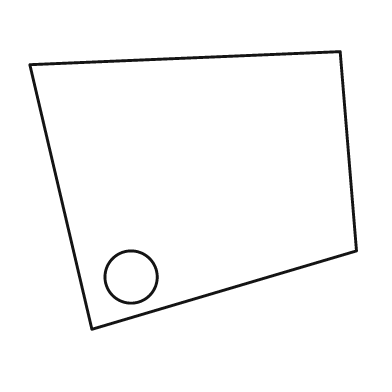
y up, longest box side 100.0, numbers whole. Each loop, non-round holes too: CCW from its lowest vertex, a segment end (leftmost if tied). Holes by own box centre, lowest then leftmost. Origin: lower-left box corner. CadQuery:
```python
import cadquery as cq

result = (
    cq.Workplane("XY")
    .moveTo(19.0, 0.0)
    .lineTo(100.0, 24.0)
    .lineTo(95.0, 85.0)
    .lineTo(0.0, 81.0)
    .close()
    .moveTo(31.0, 16.0)
    .circle(8.0)
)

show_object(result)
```